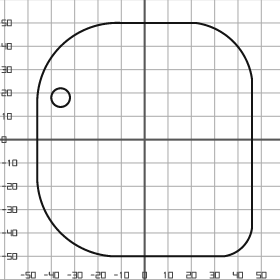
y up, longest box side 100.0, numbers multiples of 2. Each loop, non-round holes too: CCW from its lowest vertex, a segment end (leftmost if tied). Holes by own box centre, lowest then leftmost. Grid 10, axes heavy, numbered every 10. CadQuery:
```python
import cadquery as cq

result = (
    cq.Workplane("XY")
    .moveTo(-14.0, -50.0)
    .lineTo(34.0, -50.0)
    .threePointArc((42.0, -46.0), (46.0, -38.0))
    .lineTo(46.0, 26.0)
    .threePointArc((38.0, 42.0), (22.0, 50.0))
    .lineTo(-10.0, 50.0)
    .threePointArc((-36.0, 40.0), (-46.0, 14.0))
    .lineTo(-46.0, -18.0)
    .threePointArc((-36.0, -40.0), (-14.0, -50.0))
    .close()
    .moveTo(-36.0, 18.0)
    .circle(4.0)
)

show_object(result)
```